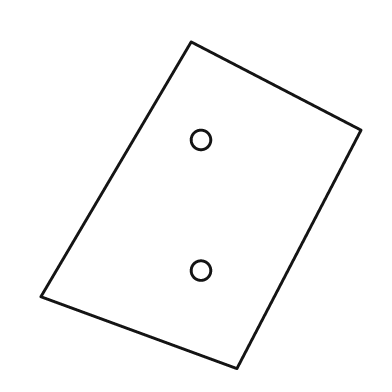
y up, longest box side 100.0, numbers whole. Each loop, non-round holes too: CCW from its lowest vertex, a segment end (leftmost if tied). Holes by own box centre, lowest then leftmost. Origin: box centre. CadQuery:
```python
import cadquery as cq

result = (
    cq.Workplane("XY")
    .moveTo(11.0, -50.0)
    .lineTo(49.0, 23.0)
    .lineTo(-3.0, 50.0)
    .lineTo(-49.0, -28.0)
    .close()
    .moveTo(0.0, -20.0)
    .circle(3.0)
    .moveTo(0.0, 20.0)
    .circle(3.0)
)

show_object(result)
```